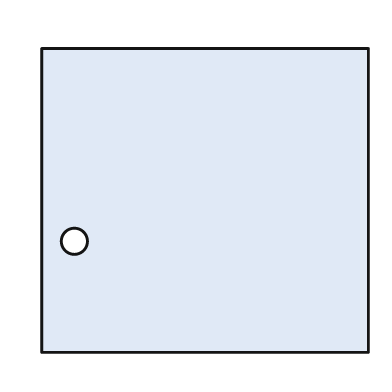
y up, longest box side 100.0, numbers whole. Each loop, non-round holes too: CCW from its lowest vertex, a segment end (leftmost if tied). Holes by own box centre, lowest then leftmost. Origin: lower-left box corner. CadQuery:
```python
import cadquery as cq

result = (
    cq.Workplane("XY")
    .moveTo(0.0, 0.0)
    .lineTo(100.0, 0.0)
    .lineTo(100.0, 93.0)
    .lineTo(0.0, 93.0)
    .close()
    .moveTo(10.0, 34.0)
    .circle(4.0)
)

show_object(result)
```